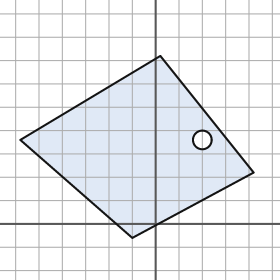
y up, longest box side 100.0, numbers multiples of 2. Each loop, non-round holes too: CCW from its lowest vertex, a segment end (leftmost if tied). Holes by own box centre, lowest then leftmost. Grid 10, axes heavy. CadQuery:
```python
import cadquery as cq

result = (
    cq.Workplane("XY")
    .moveTo(-10.0, -6.0)
    .lineTo(42.0, 22.0)
    .lineTo(2.0, 72.0)
    .lineTo(-58.0, 36.0)
    .close()
    .moveTo(20.0, 36.0)
    .circle(4.0)
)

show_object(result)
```